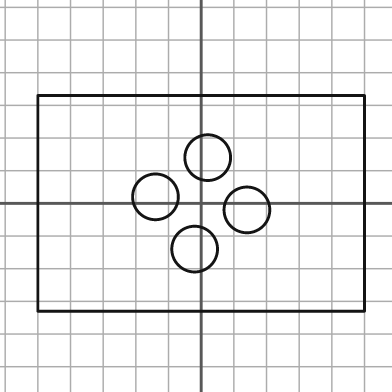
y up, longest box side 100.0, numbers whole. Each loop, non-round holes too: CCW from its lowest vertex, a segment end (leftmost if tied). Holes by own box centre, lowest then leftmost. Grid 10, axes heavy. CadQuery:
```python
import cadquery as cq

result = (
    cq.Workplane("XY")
    .moveTo(-50.0, -33.0)
    .lineTo(50.0, -33.0)
    .lineTo(50.0, 33.0)
    .lineTo(-50.0, 33.0)
    .close()
    .moveTo(-2.0, -14.0)
    .circle(7.0)
    .moveTo(14.0, -2.0)
    .circle(7.0)
    .moveTo(-14.0, 2.0)
    .circle(7.0)
    .moveTo(2.0, 14.0)
    .circle(7.0)
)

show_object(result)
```